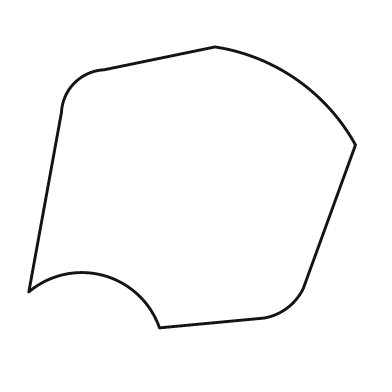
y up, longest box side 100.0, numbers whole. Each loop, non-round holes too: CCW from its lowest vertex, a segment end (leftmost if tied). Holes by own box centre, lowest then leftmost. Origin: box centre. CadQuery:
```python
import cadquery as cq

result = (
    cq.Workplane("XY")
    .moveTo(-10.0, -43.0)
    .lineTo(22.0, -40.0)
    .threePointArc((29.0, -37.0), (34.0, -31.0))
    .lineTo(50.0, 13.0)
    .threePointArc((32.0, 33.0), (7.0, 43.0))
    .lineTo(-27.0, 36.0)
    .threePointArc((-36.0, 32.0), (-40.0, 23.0))
    .lineTo(-50.0, -32.0)
    .threePointArc((-27.0, -27.0), (-10.0, -43.0))
    .close()
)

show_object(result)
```